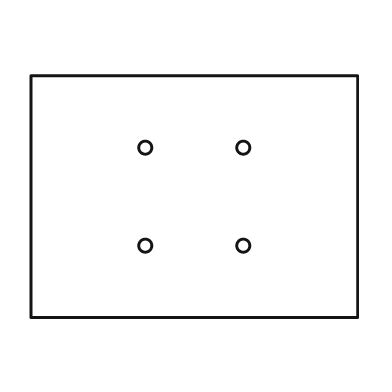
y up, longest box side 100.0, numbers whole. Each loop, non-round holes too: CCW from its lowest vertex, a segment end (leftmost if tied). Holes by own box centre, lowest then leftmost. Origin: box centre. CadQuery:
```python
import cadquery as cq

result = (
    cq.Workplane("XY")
    .moveTo(-50.0, -37.0)
    .lineTo(50.0, -37.0)
    .lineTo(50.0, 37.0)
    .lineTo(-50.0, 37.0)
    .close()
    .moveTo(-15.0, -15.0)
    .circle(2.0)
    .moveTo(15.0, -15.0)
    .circle(2.0)
    .moveTo(-15.0, 15.0)
    .circle(2.0)
    .moveTo(15.0, 15.0)
    .circle(2.0)
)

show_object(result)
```